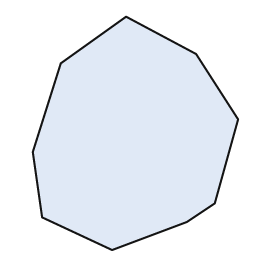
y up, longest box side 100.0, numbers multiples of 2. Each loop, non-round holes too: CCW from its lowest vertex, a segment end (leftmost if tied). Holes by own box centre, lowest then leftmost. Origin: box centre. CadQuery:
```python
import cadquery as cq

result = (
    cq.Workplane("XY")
    .moveTo(-10.0, -50.0)
    .lineTo(22.0, -38.0)
    .lineTo(34.0, -30.0)
    .lineTo(44.0, 6.0)
    .lineTo(26.0, 34.0)
    .lineTo(-4.0, 50.0)
    .lineTo(-32.0, 30.0)
    .lineTo(-44.0, -8.0)
    .lineTo(-40.0, -36.0)
    .close()
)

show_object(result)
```